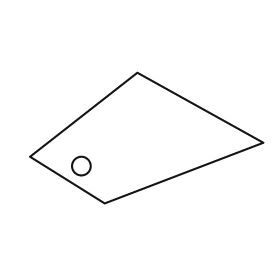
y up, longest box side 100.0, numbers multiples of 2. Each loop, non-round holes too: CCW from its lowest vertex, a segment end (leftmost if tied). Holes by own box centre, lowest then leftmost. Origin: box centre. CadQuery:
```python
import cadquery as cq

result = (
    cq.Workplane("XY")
    .moveTo(-18.0, -28.0)
    .lineTo(50.0, -2.0)
    .lineTo(-4.0, 28.0)
    .lineTo(-50.0, -8.0)
    .close()
    .moveTo(-28.0, -12.0)
    .circle(4.0)
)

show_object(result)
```